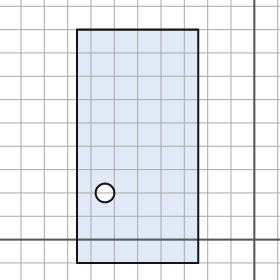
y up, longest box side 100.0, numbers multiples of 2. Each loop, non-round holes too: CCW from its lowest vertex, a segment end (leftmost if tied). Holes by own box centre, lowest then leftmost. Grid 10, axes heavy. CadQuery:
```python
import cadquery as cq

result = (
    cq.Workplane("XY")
    .moveTo(-76.0, -10.0)
    .lineTo(-24.0, -10.0)
    .lineTo(-24.0, 90.0)
    .lineTo(-76.0, 90.0)
    .close()
    .moveTo(-64.0, 20.0)
    .circle(4.0)
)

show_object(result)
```